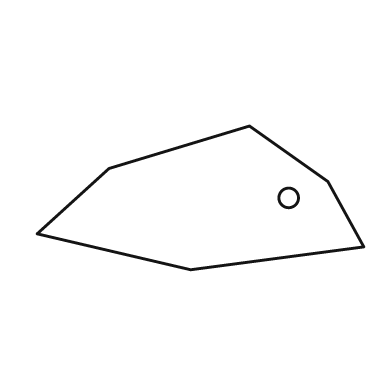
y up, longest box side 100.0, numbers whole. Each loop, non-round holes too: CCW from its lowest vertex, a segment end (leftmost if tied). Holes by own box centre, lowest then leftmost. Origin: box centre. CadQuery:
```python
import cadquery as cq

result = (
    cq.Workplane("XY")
    .moveTo(-3.0, -22.0)
    .lineTo(50.0, -15.0)
    .lineTo(39.0, 5.0)
    .lineTo(15.0, 22.0)
    .lineTo(-28.0, 9.0)
    .lineTo(-50.0, -11.0)
    .close()
    .moveTo(27.0, 0.0)
    .circle(3.0)
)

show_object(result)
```